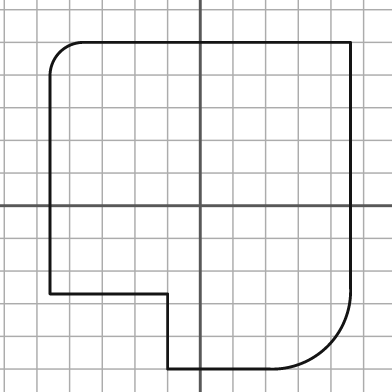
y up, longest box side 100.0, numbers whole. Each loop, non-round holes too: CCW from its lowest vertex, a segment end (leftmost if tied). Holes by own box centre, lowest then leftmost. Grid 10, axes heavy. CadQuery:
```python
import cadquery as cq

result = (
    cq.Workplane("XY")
    .moveTo(-10.0, -50.0)
    .lineTo(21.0, -50.0)
    .threePointArc((39.0, -43.0), (46.0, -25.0))
    .lineTo(46.0, 50.0)
    .lineTo(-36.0, 50.0)
    .threePointArc((-43.0, 47.0), (-46.0, 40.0))
    .lineTo(-46.0, -27.0)
    .lineTo(-10.0, -27.0)
    .close()
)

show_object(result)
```